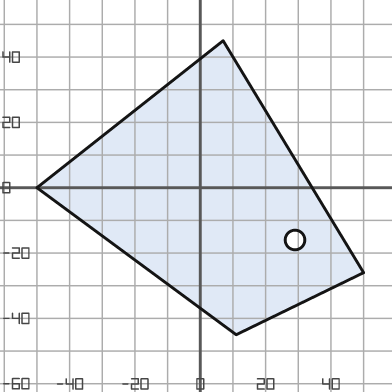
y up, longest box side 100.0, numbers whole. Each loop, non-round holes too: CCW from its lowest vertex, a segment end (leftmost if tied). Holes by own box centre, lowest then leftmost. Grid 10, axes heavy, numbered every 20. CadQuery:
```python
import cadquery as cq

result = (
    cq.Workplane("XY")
    .moveTo(11.0, -45.0)
    .lineTo(50.0, -26.0)
    .lineTo(7.0, 45.0)
    .lineTo(-50.0, 0.0)
    .close()
    .moveTo(29.0, -16.0)
    .circle(3.0)
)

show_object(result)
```